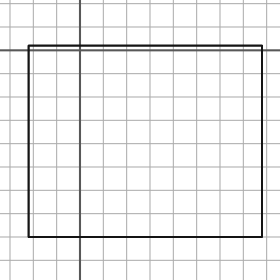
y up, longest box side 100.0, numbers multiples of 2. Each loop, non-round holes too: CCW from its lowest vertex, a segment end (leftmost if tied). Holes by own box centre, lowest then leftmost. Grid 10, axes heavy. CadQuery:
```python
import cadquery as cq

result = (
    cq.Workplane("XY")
    .moveTo(-22.0, -80.0)
    .lineTo(78.0, -80.0)
    .lineTo(78.0, 2.0)
    .lineTo(-22.0, 2.0)
    .close()
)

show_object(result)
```